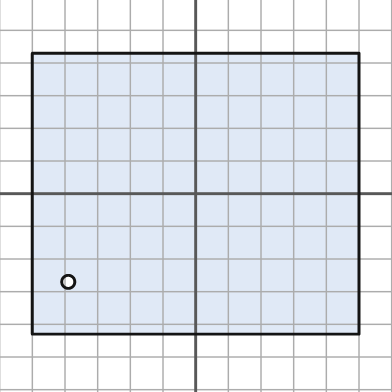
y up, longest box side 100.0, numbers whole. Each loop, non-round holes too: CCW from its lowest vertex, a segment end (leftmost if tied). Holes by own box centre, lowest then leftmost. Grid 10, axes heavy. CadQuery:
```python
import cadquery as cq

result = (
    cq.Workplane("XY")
    .moveTo(-50.0, -43.0)
    .lineTo(50.0, -43.0)
    .lineTo(50.0, 43.0)
    .lineTo(-50.0, 43.0)
    .close()
    .moveTo(-39.0, -27.0)
    .circle(2.0)
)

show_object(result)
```